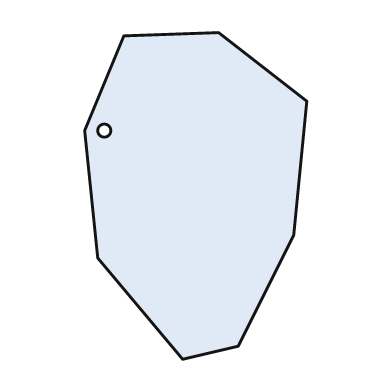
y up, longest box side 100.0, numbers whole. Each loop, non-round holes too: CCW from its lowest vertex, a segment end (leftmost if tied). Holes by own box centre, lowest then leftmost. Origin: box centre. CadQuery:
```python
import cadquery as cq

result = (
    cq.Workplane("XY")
    .moveTo(-4.0, -50.0)
    .lineTo(13.0, -46.0)
    .lineTo(30.0, -12.0)
    .lineTo(34.0, 29.0)
    .lineTo(7.0, 50.0)
    .lineTo(-22.0, 49.0)
    .lineTo(-34.0, 20.0)
    .lineTo(-30.0, -19.0)
    .close()
    .moveTo(-28.0, 20.0)
    .circle(2.0)
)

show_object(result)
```